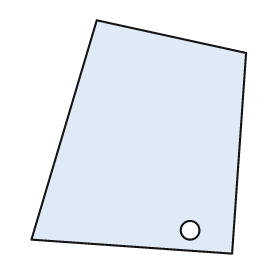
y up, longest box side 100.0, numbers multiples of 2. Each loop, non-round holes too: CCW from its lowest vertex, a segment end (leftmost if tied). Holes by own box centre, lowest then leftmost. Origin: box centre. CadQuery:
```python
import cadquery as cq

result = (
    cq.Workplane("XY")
    .moveTo(40.0, -50.0)
    .lineTo(46.0, 36.0)
    .lineTo(-18.0, 50.0)
    .lineTo(-46.0, -44.0)
    .close()
    .moveTo(22.0, -40.0)
    .circle(4.0)
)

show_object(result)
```